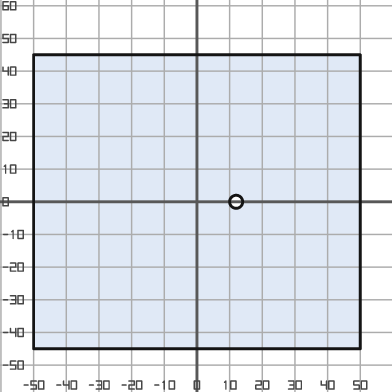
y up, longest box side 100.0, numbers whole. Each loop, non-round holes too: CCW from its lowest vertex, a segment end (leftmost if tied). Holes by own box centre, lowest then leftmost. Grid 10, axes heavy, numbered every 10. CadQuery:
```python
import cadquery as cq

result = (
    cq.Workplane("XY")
    .moveTo(-50.0, -45.0)
    .lineTo(50.0, -45.0)
    .lineTo(50.0, 45.0)
    .lineTo(-50.0, 45.0)
    .close()
    .moveTo(12.0, 0.0)
    .circle(2.0)
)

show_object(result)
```